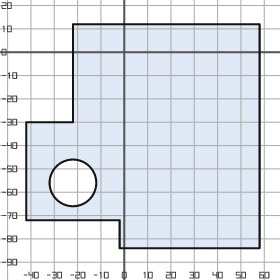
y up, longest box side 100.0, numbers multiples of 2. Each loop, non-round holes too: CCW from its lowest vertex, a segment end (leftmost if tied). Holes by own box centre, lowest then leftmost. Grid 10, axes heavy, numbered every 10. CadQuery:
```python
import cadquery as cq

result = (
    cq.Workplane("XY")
    .moveTo(-2.0, -84.0)
    .lineTo(58.0, -84.0)
    .lineTo(58.0, 12.0)
    .lineTo(-22.0, 12.0)
    .lineTo(-22.0, -30.0)
    .lineTo(-42.0, -30.0)
    .lineTo(-42.0, -72.0)
    .lineTo(-2.0, -72.0)
    .close()
    .moveTo(-22.0, -56.0)
    .circle(10.0)
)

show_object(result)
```